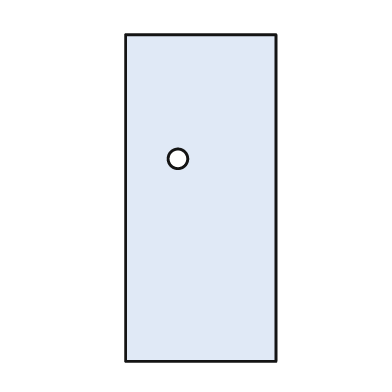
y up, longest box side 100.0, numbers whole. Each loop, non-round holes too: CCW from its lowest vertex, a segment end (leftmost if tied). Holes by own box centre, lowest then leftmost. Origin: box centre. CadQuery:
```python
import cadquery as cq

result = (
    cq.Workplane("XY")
    .moveTo(-23.0, -50.0)
    .lineTo(23.0, -50.0)
    .lineTo(23.0, 50.0)
    .lineTo(-23.0, 50.0)
    .close()
    .moveTo(-7.0, 12.0)
    .circle(3.0)
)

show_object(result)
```